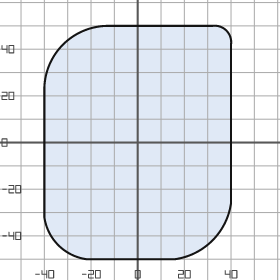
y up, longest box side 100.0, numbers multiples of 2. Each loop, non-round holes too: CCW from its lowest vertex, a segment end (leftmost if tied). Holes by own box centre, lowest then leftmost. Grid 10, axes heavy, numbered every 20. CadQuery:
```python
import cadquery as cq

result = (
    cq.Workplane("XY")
    .moveTo(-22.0, -50.0)
    .lineTo(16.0, -50.0)
    .threePointArc((32.0, -42.0), (40.0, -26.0))
    .lineTo(40.0, 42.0)
    .threePointArc((38.0, 48.0), (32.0, 50.0))
    .lineTo(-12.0, 50.0)
    .threePointArc((-32.0, 42.0), (-40.0, 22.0))
    .lineTo(-40.0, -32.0)
    .threePointArc((-34.0, -44.0), (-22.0, -50.0))
    .close()
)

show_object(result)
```